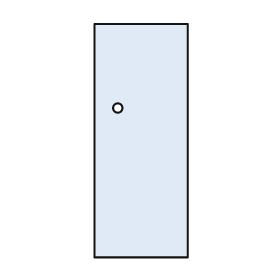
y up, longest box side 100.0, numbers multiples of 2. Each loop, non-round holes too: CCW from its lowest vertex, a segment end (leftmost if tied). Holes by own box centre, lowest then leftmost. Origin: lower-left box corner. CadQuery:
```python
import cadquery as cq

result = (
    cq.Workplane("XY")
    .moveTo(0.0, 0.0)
    .lineTo(40.0, 0.0)
    .lineTo(40.0, 100.0)
    .lineTo(0.0, 100.0)
    .close()
    .moveTo(10.0, 64.0)
    .circle(2.0)
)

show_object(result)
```